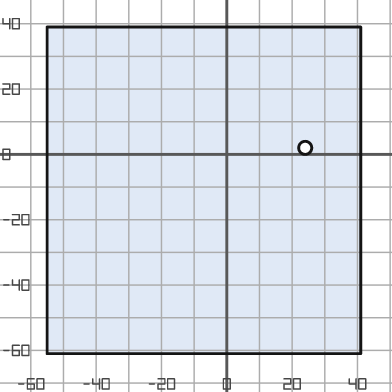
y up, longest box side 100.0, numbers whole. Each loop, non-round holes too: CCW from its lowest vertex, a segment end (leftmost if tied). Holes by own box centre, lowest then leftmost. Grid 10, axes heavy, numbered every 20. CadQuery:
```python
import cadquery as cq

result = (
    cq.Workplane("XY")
    .moveTo(-55.0, -61.0)
    .lineTo(41.0, -61.0)
    .lineTo(41.0, 39.0)
    .lineTo(-55.0, 39.0)
    .close()
    .moveTo(24.0, 2.0)
    .circle(2.0)
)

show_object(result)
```